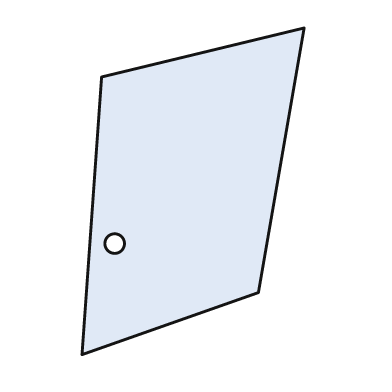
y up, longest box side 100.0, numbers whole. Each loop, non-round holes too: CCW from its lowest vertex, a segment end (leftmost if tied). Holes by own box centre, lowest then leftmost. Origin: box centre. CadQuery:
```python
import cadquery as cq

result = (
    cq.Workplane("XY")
    .moveTo(-34.0, -50.0)
    .lineTo(20.0, -31.0)
    .lineTo(34.0, 50.0)
    .lineTo(-28.0, 35.0)
    .close()
    .moveTo(-24.0, -16.0)
    .circle(3.0)
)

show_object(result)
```